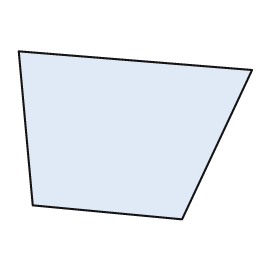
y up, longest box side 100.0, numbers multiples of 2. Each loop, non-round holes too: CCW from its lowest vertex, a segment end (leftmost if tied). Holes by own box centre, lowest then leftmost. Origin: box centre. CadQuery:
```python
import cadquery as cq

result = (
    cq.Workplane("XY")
    .moveTo(20.0, -36.0)
    .lineTo(50.0, 28.0)
    .lineTo(-50.0, 36.0)
    .lineTo(-44.0, -30.0)
    .close()
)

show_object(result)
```